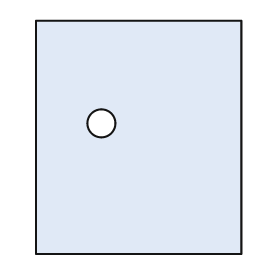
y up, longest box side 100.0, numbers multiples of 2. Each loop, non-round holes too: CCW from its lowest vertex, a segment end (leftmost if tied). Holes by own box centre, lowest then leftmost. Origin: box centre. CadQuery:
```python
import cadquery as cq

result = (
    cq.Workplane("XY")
    .moveTo(-44.0, -50.0)
    .lineTo(44.0, -50.0)
    .lineTo(44.0, 50.0)
    .lineTo(-44.0, 50.0)
    .close()
    .moveTo(-16.0, 6.0)
    .circle(6.0)
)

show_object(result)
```